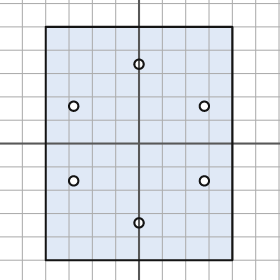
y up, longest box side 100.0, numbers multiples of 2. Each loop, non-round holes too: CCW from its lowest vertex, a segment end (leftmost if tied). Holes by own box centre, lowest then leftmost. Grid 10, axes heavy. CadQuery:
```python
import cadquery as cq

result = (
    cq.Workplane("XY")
    .moveTo(-40.0, -50.0)
    .lineTo(40.0, -50.0)
    .lineTo(40.0, 50.0)
    .lineTo(-40.0, 50.0)
    .close()
    .moveTo(0.0, -34.0)
    .circle(2.0)
    .moveTo(-28.0, -16.0)
    .circle(2.0)
    .moveTo(28.0, -16.0)
    .circle(2.0)
    .moveTo(-28.0, 16.0)
    .circle(2.0)
    .moveTo(28.0, 16.0)
    .circle(2.0)
    .moveTo(0.0, 34.0)
    .circle(2.0)
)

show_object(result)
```